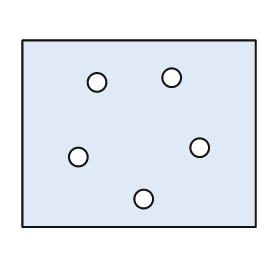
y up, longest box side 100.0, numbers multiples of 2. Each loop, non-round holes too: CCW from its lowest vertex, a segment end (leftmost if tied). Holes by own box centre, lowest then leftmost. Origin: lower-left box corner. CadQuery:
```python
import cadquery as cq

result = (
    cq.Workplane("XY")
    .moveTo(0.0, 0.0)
    .lineTo(100.0, 0.0)
    .lineTo(100.0, 80.0)
    .lineTo(0.0, 80.0)
    .close()
    .moveTo(52.0, 12.0)
    .circle(4.0)
    .moveTo(24.0, 30.0)
    .circle(4.0)
    .moveTo(76.0, 34.0)
    .circle(4.0)
    .moveTo(32.0, 62.0)
    .circle(4.0)
    .moveTo(64.0, 64.0)
    .circle(4.0)
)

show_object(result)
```